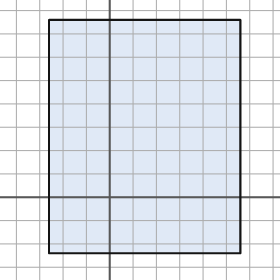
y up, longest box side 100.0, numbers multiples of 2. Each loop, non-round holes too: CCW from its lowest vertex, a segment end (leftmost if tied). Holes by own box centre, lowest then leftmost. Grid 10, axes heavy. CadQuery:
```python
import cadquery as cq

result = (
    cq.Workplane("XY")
    .moveTo(-26.0, -24.0)
    .lineTo(56.0, -24.0)
    .lineTo(56.0, 76.0)
    .lineTo(-26.0, 76.0)
    .close()
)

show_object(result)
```